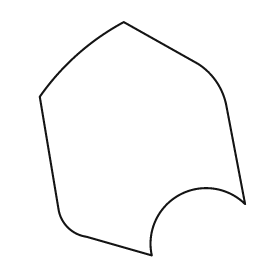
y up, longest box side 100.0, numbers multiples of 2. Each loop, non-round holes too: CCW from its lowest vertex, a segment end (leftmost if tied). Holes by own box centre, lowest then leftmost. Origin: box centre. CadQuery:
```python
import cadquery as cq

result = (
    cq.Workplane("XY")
    .moveTo(4.0, -50.0)
    .threePointArc((16.0, -24.0), (44.0, -28.0))
    .lineTo(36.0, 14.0)
    .threePointArc((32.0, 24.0), (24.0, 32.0))
    .lineTo(-8.0, 50.0)
    .threePointArc((-28.0, 36.0), (-44.0, 18.0))
    .lineTo(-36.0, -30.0)
    .threePointArc((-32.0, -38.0), (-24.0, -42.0))
    .close()
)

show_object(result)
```